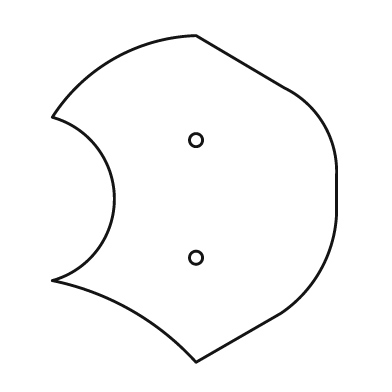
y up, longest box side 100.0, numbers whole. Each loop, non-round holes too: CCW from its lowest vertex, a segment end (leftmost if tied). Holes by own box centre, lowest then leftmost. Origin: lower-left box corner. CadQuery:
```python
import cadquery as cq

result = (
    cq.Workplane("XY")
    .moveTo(44.0, 0.0)
    .lineTo(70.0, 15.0)
    .threePointArc((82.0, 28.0), (87.0, 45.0))
    .lineTo(87.0, 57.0)
    .threePointArc((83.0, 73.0), (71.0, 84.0))
    .lineTo(44.0, 100.0)
    .threePointArc((19.0, 93.0), (0.0, 75.0))
    .threePointArc((19.0, 50.0), (0.0, 25.0))
    .threePointArc((24.0, 16.0), (44.0, 0.0))
    .close()
    .moveTo(44.0, 32.0)
    .circle(2.0)
    .moveTo(44.0, 68.0)
    .circle(2.0)
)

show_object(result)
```